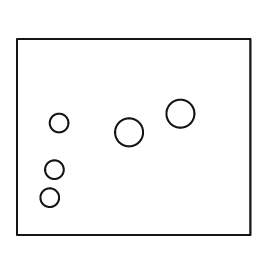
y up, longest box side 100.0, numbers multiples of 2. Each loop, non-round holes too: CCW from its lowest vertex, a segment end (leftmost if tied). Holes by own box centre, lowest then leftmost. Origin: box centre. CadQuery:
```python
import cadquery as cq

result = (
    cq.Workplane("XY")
    .moveTo(-50.0, -42.0)
    .lineTo(50.0, -42.0)
    .lineTo(50.0, 42.0)
    .lineTo(-50.0, 42.0)
    .close()
    .moveTo(-36.0, -26.0)
    .circle(4.0)
    .moveTo(-34.0, -14.0)
    .circle(4.0)
    .moveTo(-2.0, 2.0)
    .circle(6.0)
    .moveTo(-32.0, 6.0)
    .circle(4.0)
    .moveTo(20.0, 10.0)
    .circle(6.0)
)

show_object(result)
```